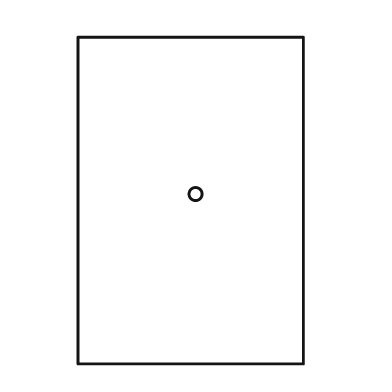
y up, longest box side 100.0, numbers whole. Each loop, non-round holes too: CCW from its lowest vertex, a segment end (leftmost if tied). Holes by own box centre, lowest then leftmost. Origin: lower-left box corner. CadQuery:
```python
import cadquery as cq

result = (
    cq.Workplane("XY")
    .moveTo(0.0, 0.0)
    .lineTo(69.0, 0.0)
    .lineTo(69.0, 100.0)
    .lineTo(0.0, 100.0)
    .close()
    .moveTo(36.0, 52.0)
    .circle(2.0)
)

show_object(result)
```